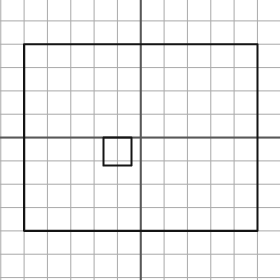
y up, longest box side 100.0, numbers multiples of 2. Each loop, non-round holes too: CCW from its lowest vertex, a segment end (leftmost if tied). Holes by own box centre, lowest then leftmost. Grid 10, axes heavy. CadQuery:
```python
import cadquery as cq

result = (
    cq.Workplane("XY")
    .moveTo(-50.0, -40.0)
    .lineTo(50.0, -40.0)
    .lineTo(50.0, 40.0)
    .lineTo(-50.0, 40.0)
    .close()
    .moveTo(-16.0, -12.0)
    .lineTo(-4.0, -12.0)
    .lineTo(-4.0, 0.0)
    .lineTo(-16.0, 0.0)
    .close()
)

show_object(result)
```